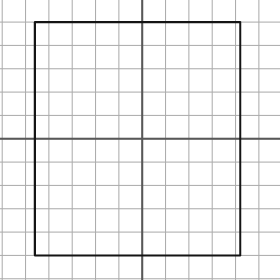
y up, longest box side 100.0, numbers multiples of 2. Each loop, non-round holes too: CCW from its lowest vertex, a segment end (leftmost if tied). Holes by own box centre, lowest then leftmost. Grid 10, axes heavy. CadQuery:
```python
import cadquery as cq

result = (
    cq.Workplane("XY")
    .moveTo(-46.0, -50.0)
    .lineTo(42.0, -50.0)
    .lineTo(42.0, 50.0)
    .lineTo(-46.0, 50.0)
    .close()
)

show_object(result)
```